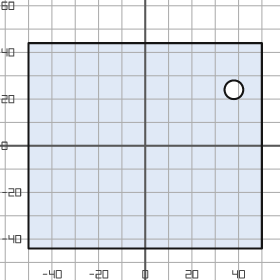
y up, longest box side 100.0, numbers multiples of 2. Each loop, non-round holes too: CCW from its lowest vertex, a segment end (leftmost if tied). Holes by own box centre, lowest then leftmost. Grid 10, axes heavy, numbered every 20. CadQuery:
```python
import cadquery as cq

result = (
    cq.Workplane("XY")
    .moveTo(-50.0, -44.0)
    .lineTo(50.0, -44.0)
    .lineTo(50.0, 44.0)
    .lineTo(-50.0, 44.0)
    .close()
    .moveTo(38.0, 24.0)
    .circle(4.0)
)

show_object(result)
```